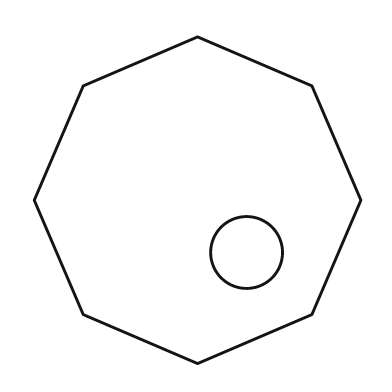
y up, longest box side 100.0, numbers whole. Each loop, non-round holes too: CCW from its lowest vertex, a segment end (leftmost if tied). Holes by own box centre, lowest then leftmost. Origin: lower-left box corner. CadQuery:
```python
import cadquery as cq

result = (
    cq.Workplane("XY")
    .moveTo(50.0, 0.0)
    .lineTo(85.0, 15.0)
    .lineTo(100.0, 50.0)
    .lineTo(85.0, 85.0)
    .lineTo(50.0, 100.0)
    .lineTo(15.0, 85.0)
    .lineTo(0.0, 50.0)
    .lineTo(15.0, 15.0)
    .close()
    .moveTo(65.0, 34.0)
    .circle(11.0)
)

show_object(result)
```